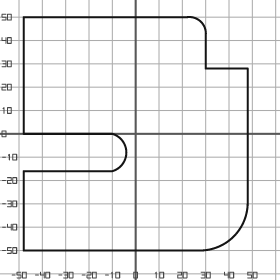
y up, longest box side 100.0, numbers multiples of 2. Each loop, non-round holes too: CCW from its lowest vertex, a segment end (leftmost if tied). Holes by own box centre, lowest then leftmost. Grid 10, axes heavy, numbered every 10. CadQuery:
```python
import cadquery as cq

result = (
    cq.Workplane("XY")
    .moveTo(-48.0, -50.0)
    .lineTo(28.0, -50.0)
    .threePointArc((42.0, -44.0), (48.0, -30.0))
    .lineTo(48.0, 28.0)
    .lineTo(30.0, 28.0)
    .lineTo(30.0, 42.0)
    .threePointArc((28.0, 48.0), (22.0, 50.0))
    .lineTo(-48.0, 50.0)
    .lineTo(-48.0, 0.0)
    .lineTo(-10.0, 0.0)
    .threePointArc((-4.0, -8.0), (-10.0, -16.0))
    .lineTo(-48.0, -16.0)
    .close()
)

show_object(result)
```